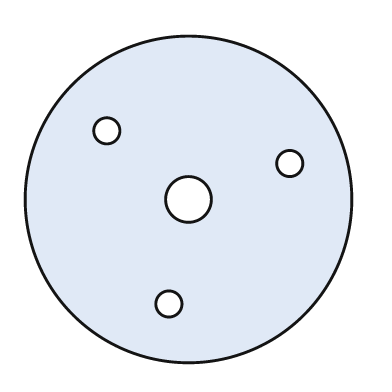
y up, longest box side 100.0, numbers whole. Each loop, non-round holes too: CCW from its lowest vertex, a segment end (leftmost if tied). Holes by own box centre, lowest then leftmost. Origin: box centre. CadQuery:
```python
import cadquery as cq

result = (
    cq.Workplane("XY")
    .moveTo(0.0, 0.0)
    .circle(50.0)
    .moveTo(-6.0, -32.0)
    .circle(4.0)
    .moveTo(0.0, 0.0)
    .circle(7.0)
    .moveTo(31.0, 11.0)
    .circle(4.0)
    .moveTo(-25.0, 21.0)
    .circle(4.0)
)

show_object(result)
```